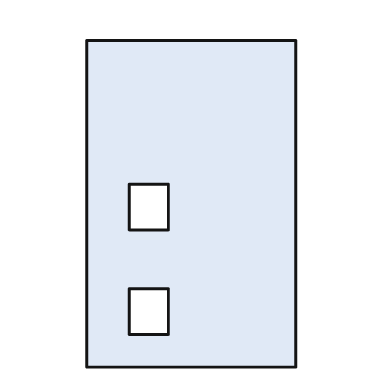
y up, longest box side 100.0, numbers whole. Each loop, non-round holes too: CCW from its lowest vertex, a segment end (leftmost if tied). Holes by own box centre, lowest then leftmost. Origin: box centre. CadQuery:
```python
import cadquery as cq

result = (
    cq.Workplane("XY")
    .moveTo(-32.0, -50.0)
    .lineTo(32.0, -50.0)
    .lineTo(32.0, 50.0)
    .lineTo(-32.0, 50.0)
    .close()
    .moveTo(-19.0, -40.0)
    .lineTo(-7.0, -40.0)
    .lineTo(-7.0, -26.0)
    .lineTo(-19.0, -26.0)
    .close()
    .moveTo(-19.0, -8.0)
    .lineTo(-7.0, -8.0)
    .lineTo(-7.0, 6.0)
    .lineTo(-19.0, 6.0)
    .close()
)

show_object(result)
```